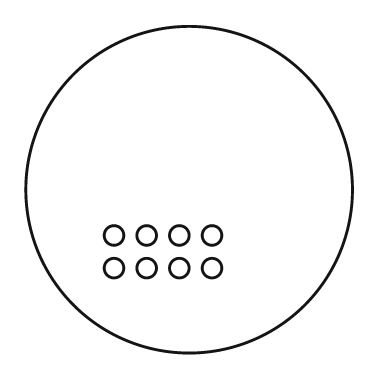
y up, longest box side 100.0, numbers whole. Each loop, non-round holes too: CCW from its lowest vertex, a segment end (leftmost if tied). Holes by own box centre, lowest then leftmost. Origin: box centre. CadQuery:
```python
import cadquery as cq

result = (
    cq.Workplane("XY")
    .moveTo(0.0, 0.0)
    .circle(50.0)
    .moveTo(-23.0, -24.0)
    .circle(3.0)
    .moveTo(-13.0, -24.0)
    .circle(3.0)
    .moveTo(-3.0, -24.0)
    .circle(3.0)
    .moveTo(7.0, -24.0)
    .circle(3.0)
    .moveTo(-23.0, -14.0)
    .circle(3.0)
    .moveTo(-13.0, -14.0)
    .circle(3.0)
    .moveTo(-3.0, -14.0)
    .circle(3.0)
    .moveTo(7.0, -14.0)
    .circle(3.0)
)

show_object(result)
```